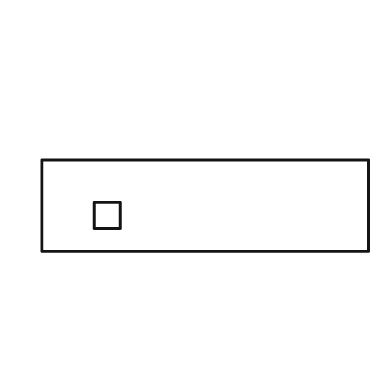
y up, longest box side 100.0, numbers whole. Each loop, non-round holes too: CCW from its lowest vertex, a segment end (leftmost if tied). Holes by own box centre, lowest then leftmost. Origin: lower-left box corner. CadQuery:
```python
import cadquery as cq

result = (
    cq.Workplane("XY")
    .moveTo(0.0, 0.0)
    .lineTo(100.0, 0.0)
    .lineTo(100.0, 28.0)
    .lineTo(0.0, 28.0)
    .close()
    .moveTo(16.0, 7.0)
    .lineTo(24.0, 7.0)
    .lineTo(24.0, 15.0)
    .lineTo(16.0, 15.0)
    .close()
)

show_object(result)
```